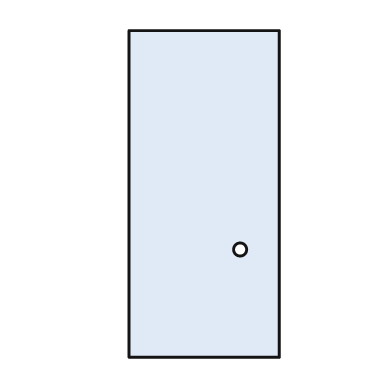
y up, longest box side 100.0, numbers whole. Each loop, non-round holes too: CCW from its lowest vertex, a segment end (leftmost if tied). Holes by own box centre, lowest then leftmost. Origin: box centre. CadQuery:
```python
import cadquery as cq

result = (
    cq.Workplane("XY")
    .moveTo(-23.0, -50.0)
    .lineTo(23.0, -50.0)
    .lineTo(23.0, 50.0)
    .lineTo(-23.0, 50.0)
    .close()
    .moveTo(11.0, -17.0)
    .circle(2.0)
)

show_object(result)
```